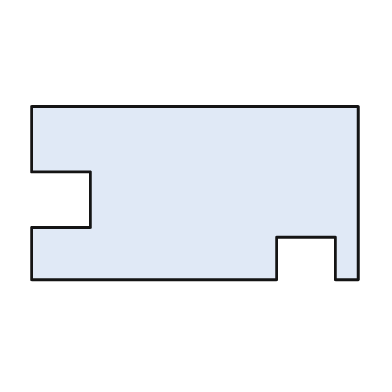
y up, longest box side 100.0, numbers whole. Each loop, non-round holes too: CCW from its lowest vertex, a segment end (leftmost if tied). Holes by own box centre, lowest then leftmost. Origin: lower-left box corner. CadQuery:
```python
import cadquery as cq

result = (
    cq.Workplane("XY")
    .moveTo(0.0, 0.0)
    .lineTo(75.0, 0.0)
    .lineTo(75.0, 13.0)
    .lineTo(93.0, 13.0)
    .lineTo(93.0, 0.0)
    .lineTo(100.0, 0.0)
    .lineTo(100.0, 53.0)
    .lineTo(0.0, 53.0)
    .lineTo(0.0, 33.0)
    .lineTo(18.0, 33.0)
    .lineTo(18.0, 16.0)
    .lineTo(0.0, 16.0)
    .close()
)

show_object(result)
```